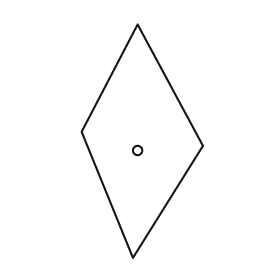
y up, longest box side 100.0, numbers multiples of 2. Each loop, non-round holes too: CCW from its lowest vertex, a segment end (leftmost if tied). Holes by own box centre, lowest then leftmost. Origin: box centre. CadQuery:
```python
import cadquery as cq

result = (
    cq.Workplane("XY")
    .moveTo(-4.0, -50.0)
    .lineTo(26.0, -2.0)
    .lineTo(-2.0, 50.0)
    .lineTo(-26.0, 4.0)
    .close()
    .moveTo(-2.0, -4.0)
    .circle(2.0)
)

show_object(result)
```